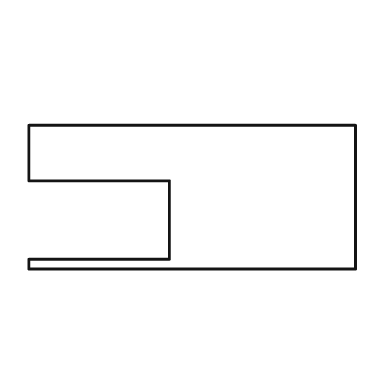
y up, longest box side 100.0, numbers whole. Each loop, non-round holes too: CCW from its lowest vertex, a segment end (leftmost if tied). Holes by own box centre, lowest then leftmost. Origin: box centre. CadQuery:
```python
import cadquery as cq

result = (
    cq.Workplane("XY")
    .moveTo(-50.0, -22.0)
    .lineTo(50.0, -22.0)
    .lineTo(50.0, 22.0)
    .lineTo(-50.0, 22.0)
    .lineTo(-50.0, 5.0)
    .lineTo(-7.0, 5.0)
    .lineTo(-7.0, -19.0)
    .lineTo(-50.0, -19.0)
    .close()
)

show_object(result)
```